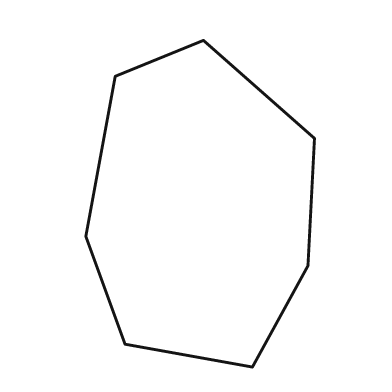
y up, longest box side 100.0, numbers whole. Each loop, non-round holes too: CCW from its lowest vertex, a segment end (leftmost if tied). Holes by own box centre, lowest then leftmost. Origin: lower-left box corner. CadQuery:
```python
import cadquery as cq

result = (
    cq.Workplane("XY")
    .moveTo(51.0, 0.0)
    .lineTo(68.0, 31.0)
    .lineTo(70.0, 70.0)
    .lineTo(36.0, 100.0)
    .lineTo(9.0, 89.0)
    .lineTo(0.0, 40.0)
    .lineTo(12.0, 7.0)
    .close()
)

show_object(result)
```